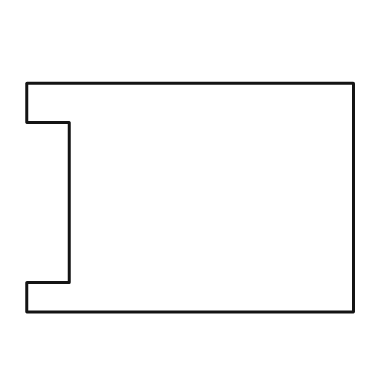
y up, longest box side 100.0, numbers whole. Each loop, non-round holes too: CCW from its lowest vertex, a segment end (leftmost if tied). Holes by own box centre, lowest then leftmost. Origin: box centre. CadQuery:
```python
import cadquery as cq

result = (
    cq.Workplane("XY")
    .moveTo(-50.0, -35.0)
    .lineTo(50.0, -35.0)
    .lineTo(50.0, 35.0)
    .lineTo(-50.0, 35.0)
    .lineTo(-50.0, 23.0)
    .lineTo(-37.0, 23.0)
    .lineTo(-37.0, -26.0)
    .lineTo(-50.0, -26.0)
    .close()
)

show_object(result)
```